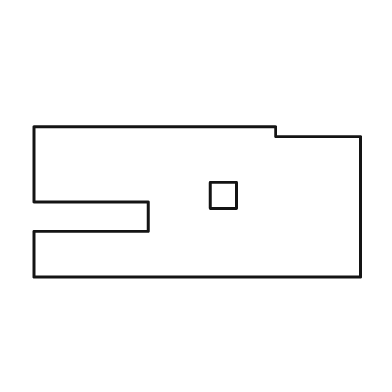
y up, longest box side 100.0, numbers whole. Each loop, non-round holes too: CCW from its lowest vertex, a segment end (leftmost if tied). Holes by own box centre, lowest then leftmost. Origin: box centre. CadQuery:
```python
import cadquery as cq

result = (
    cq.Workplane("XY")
    .moveTo(-50.0, -23.0)
    .lineTo(50.0, -23.0)
    .lineTo(50.0, 20.0)
    .lineTo(24.0, 20.0)
    .lineTo(24.0, 23.0)
    .lineTo(-50.0, 23.0)
    .lineTo(-50.0, 0.0)
    .lineTo(-15.0, 0.0)
    .lineTo(-15.0, -9.0)
    .lineTo(-50.0, -9.0)
    .close()
    .moveTo(4.0, -2.0)
    .lineTo(12.0, -2.0)
    .lineTo(12.0, 6.0)
    .lineTo(4.0, 6.0)
    .close()
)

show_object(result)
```